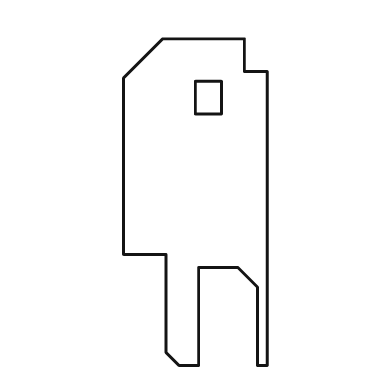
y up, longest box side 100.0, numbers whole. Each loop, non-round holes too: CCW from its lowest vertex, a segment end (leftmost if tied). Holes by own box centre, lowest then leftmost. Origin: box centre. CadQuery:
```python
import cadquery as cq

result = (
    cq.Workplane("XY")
    .moveTo(-5.0, -50.0)
    .lineTo(1.0, -50.0)
    .lineTo(1.0, -20.0)
    .lineTo(13.0, -20.0)
    .lineTo(19.0, -26.0)
    .lineTo(19.0, -50.0)
    .lineTo(22.0, -50.0)
    .lineTo(22.0, 40.0)
    .lineTo(15.0, 40.0)
    .lineTo(15.0, 50.0)
    .lineTo(-10.0, 50.0)
    .lineTo(-22.0, 38.0)
    .lineTo(-22.0, -16.0)
    .lineTo(-9.0, -16.0)
    .lineTo(-9.0, -46.0)
    .close()
    .moveTo(0.0, 27.0)
    .lineTo(8.0, 27.0)
    .lineTo(8.0, 37.0)
    .lineTo(0.0, 37.0)
    .close()
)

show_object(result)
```